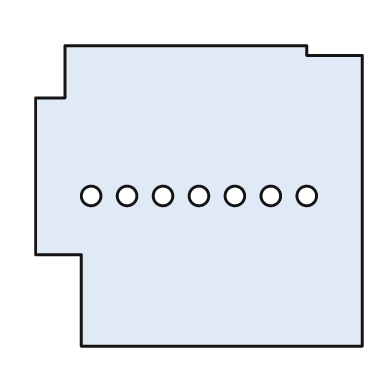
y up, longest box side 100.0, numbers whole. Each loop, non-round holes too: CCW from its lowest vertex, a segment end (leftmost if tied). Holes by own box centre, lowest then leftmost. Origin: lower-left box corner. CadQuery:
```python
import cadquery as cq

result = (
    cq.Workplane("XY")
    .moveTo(14.0, 0.0)
    .lineTo(100.0, 0.0)
    .lineTo(100.0, 89.0)
    .lineTo(83.0, 89.0)
    .lineTo(83.0, 92.0)
    .lineTo(9.0, 92.0)
    .lineTo(9.0, 76.0)
    .lineTo(0.0, 76.0)
    .lineTo(0.0, 28.0)
    .lineTo(14.0, 28.0)
    .close()
    .moveTo(17.0, 46.0)
    .circle(3.0)
    .moveTo(28.0, 46.0)
    .circle(3.0)
    .moveTo(39.0, 46.0)
    .circle(3.0)
    .moveTo(50.0, 46.0)
    .circle(3.0)
    .moveTo(61.0, 46.0)
    .circle(3.0)
    .moveTo(72.0, 46.0)
    .circle(3.0)
    .moveTo(83.0, 46.0)
    .circle(3.0)
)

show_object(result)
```